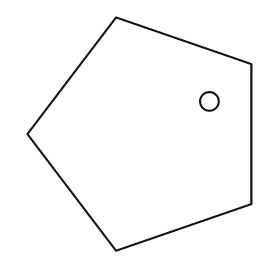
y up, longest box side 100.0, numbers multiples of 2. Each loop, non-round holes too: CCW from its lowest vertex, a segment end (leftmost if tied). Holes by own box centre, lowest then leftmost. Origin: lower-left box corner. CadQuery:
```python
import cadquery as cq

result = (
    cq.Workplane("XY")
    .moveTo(38.0, 0.0)
    .lineTo(96.0, 20.0)
    .lineTo(96.0, 80.0)
    .lineTo(38.0, 100.0)
    .lineTo(0.0, 50.0)
    .close()
    .moveTo(78.0, 64.0)
    .circle(4.0)
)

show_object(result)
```